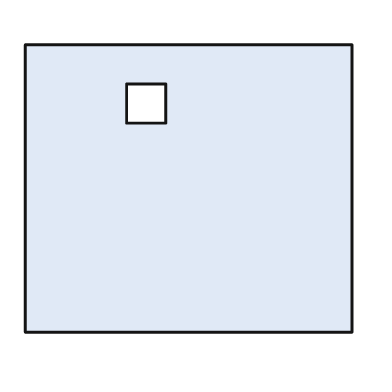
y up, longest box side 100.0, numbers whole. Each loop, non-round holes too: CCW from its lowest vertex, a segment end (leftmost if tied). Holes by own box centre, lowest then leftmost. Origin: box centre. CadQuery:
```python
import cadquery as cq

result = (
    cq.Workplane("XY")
    .moveTo(-50.0, -44.0)
    .lineTo(50.0, -44.0)
    .lineTo(50.0, 44.0)
    .lineTo(-50.0, 44.0)
    .close()
    .moveTo(-19.0, 20.0)
    .lineTo(-7.0, 20.0)
    .lineTo(-7.0, 32.0)
    .lineTo(-19.0, 32.0)
    .close()
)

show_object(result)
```